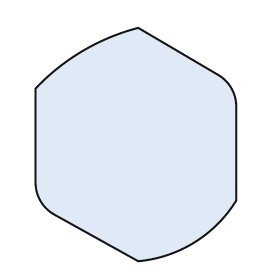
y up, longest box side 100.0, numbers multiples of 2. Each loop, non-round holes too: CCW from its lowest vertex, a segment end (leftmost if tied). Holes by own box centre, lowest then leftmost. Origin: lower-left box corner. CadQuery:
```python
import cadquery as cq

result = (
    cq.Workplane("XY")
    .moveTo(44.0, 0.0)
    .threePointArc((68.0, 8.0), (86.0, 26.0))
    .lineTo(86.0, 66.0)
    .threePointArc((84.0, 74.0), (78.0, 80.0))
    .lineTo(44.0, 100.0)
    .threePointArc((20.0, 90.0), (0.0, 74.0))
    .lineTo(0.0, 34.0)
    .threePointArc((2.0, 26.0), (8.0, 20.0))
    .close()
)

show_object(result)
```